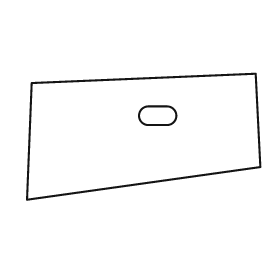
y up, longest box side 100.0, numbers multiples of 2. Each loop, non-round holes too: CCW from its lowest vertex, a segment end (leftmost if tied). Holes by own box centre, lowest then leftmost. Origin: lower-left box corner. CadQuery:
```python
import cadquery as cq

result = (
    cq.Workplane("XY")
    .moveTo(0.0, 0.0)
    .lineTo(100.0, 14.0)
    .lineTo(98.0, 54.0)
    .lineTo(2.0, 50.0)
    .close()
    .moveTo(52.0, 32.0)
    .lineTo(60.0, 32.0)
    .threePointArc((64.0, 36.0), (60.0, 40.0))
    .lineTo(52.0, 40.0)
    .threePointArc((48.0, 36.0), (52.0, 32.0))
    .close()
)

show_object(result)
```